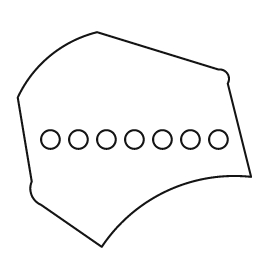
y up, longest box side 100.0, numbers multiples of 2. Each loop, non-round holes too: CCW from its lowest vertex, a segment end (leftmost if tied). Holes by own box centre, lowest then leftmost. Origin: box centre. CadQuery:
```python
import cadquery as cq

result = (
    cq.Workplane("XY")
    .moveTo(-14.0, -46.0)
    .threePointArc((14.0, -22.0), (50.0, -16.0))
    .lineTo(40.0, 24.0)
    .threePointArc((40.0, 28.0), (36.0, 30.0))
    .lineTo(-16.0, 46.0)
    .threePointArc((-36.0, 36.0), (-50.0, 18.0))
    .lineTo(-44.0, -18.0)
    .threePointArc((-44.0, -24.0), (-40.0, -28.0))
    .close()
    .moveTo(-36.0, 0.0)
    .circle(4.0)
    .moveTo(-24.0, 0.0)
    .circle(4.0)
    .moveTo(-12.0, 0.0)
    .circle(4.0)
    .moveTo(0.0, 0.0)
    .circle(4.0)
    .moveTo(12.0, 0.0)
    .circle(4.0)
    .moveTo(24.0, 0.0)
    .circle(4.0)
    .moveTo(36.0, 0.0)
    .circle(4.0)
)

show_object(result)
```